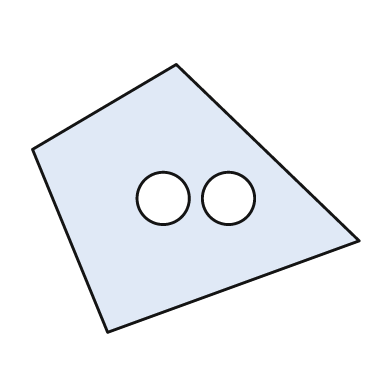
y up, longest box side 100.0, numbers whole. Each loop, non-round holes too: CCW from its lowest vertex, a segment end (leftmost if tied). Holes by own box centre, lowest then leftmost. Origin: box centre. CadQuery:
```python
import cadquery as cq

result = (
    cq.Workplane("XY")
    .moveTo(-27.0, -41.0)
    .lineTo(50.0, -13.0)
    .lineTo(-6.0, 41.0)
    .lineTo(-50.0, 15.0)
    .close()
    .moveTo(-10.0, 0.0)
    .circle(8.0)
    .moveTo(10.0, 0.0)
    .circle(8.0)
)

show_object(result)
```